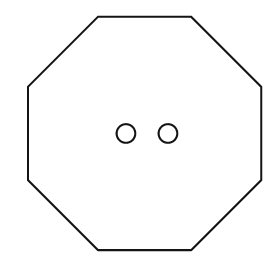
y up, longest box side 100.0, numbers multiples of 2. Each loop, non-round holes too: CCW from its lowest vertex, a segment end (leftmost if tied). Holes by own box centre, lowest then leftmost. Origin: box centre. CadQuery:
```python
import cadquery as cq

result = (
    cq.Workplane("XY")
    .moveTo(-20.0, -50.0)
    .lineTo(20.0, -50.0)
    .lineTo(50.0, -20.0)
    .lineTo(50.0, 20.0)
    .lineTo(20.0, 50.0)
    .lineTo(-20.0, 50.0)
    .lineTo(-50.0, 20.0)
    .lineTo(-50.0, -20.0)
    .close()
    .moveTo(-8.0, 0.0)
    .circle(4.0)
    .moveTo(10.0, 0.0)
    .circle(4.0)
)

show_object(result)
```